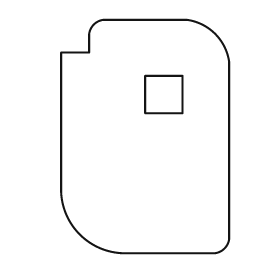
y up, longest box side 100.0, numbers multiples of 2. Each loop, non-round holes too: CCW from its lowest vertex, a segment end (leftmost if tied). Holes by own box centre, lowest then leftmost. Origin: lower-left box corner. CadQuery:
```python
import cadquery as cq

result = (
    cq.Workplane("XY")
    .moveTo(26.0, 0.0)
    .lineTo(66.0, 0.0)
    .threePointArc((70.0, 2.0), (72.0, 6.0))
    .lineTo(72.0, 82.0)
    .threePointArc((66.0, 94.0), (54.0, 100.0))
    .lineTo(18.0, 100.0)
    .threePointArc((14.0, 98.0), (12.0, 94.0))
    .lineTo(12.0, 86.0)
    .lineTo(0.0, 86.0)
    .lineTo(0.0, 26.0)
    .threePointArc((8.0, 8.0), (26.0, 0.0))
    .close()
    .moveTo(36.0, 60.0)
    .lineTo(52.0, 60.0)
    .lineTo(52.0, 76.0)
    .lineTo(36.0, 76.0)
    .close()
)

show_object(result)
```